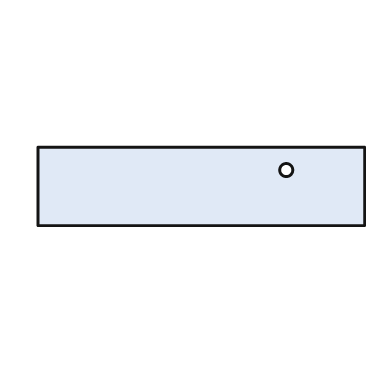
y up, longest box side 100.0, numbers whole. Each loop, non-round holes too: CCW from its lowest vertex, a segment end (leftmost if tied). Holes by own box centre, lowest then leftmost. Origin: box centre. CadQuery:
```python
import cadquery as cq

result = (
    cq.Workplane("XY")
    .moveTo(-50.0, -12.0)
    .lineTo(50.0, -12.0)
    .lineTo(50.0, 12.0)
    .lineTo(-50.0, 12.0)
    .close()
    .moveTo(26.0, 5.0)
    .circle(2.0)
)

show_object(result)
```